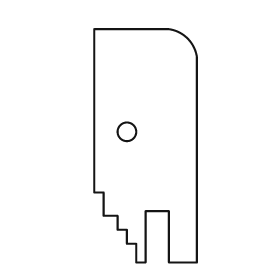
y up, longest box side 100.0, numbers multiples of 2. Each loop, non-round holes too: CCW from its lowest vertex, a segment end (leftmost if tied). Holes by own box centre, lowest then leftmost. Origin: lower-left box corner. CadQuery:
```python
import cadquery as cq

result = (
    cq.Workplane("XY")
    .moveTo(18.0, 0.0)
    .lineTo(22.0, 0.0)
    .lineTo(22.0, 22.0)
    .lineTo(32.0, 22.0)
    .lineTo(32.0, 0.0)
    .lineTo(44.0, 0.0)
    .lineTo(44.0, 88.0)
    .threePointArc((40.0, 96.0), (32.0, 100.0))
    .lineTo(0.0, 100.0)
    .lineTo(0.0, 30.0)
    .lineTo(4.0, 30.0)
    .lineTo(4.0, 20.0)
    .lineTo(10.0, 20.0)
    .lineTo(10.0, 14.0)
    .lineTo(14.0, 14.0)
    .lineTo(14.0, 8.0)
    .lineTo(18.0, 8.0)
    .close()
    .moveTo(14.0, 56.0)
    .circle(4.0)
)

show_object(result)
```